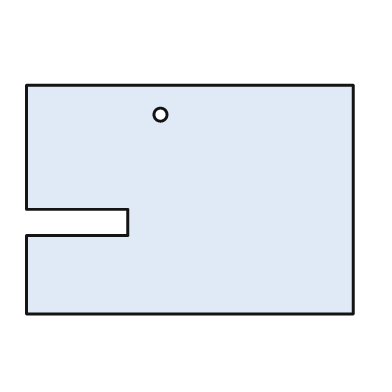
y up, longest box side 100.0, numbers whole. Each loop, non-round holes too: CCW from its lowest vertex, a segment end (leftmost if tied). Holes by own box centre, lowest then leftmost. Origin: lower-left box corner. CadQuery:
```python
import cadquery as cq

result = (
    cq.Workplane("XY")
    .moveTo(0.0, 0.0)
    .lineTo(100.0, 0.0)
    .lineTo(100.0, 70.0)
    .lineTo(0.0, 70.0)
    .lineTo(0.0, 32.0)
    .lineTo(31.0, 32.0)
    .lineTo(31.0, 24.0)
    .lineTo(0.0, 24.0)
    .close()
    .moveTo(41.0, 61.0)
    .circle(2.0)
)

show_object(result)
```